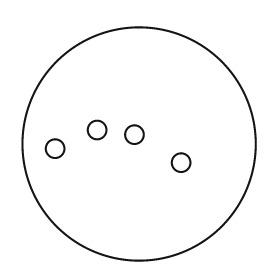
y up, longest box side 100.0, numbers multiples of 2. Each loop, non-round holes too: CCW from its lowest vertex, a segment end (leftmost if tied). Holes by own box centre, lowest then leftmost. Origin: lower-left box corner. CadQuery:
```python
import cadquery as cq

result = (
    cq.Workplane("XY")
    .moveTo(50.0, 50.0)
    .circle(50.0)
    .moveTo(68.0, 42.0)
    .circle(4.0)
    .moveTo(14.0, 48.0)
    .circle(4.0)
    .moveTo(48.0, 54.0)
    .circle(4.0)
    .moveTo(32.0, 56.0)
    .circle(4.0)
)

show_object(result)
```